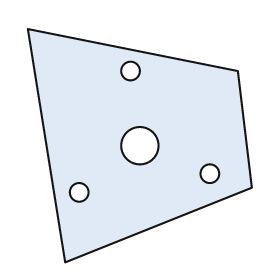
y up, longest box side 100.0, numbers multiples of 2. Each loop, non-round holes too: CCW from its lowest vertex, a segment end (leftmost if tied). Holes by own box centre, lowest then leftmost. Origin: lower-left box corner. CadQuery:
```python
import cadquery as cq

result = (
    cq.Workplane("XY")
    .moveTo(16.0, 0.0)
    .lineTo(96.0, 32.0)
    .lineTo(90.0, 82.0)
    .lineTo(0.0, 100.0)
    .close()
    .moveTo(22.0, 30.0)
    .circle(4.0)
    .moveTo(78.0, 38.0)
    .circle(4.0)
    .moveTo(48.0, 50.0)
    .circle(8.0)
    .moveTo(44.0, 82.0)
    .circle(4.0)
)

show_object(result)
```